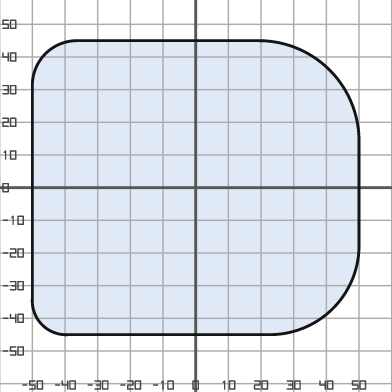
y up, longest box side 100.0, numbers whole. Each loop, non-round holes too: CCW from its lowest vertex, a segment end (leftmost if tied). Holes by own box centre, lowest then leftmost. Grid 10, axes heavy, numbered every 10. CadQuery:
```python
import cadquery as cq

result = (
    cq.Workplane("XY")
    .moveTo(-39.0, -45.0)
    .lineTo(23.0, -45.0)
    .threePointArc((42.0, -37.0), (50.0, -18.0))
    .lineTo(50.0, 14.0)
    .threePointArc((41.0, 36.0), (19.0, 45.0))
    .lineTo(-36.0, 45.0)
    .threePointArc((-46.0, 41.0), (-50.0, 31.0))
    .lineTo(-50.0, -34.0)
    .threePointArc((-47.0, -42.0), (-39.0, -45.0))
    .close()
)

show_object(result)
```